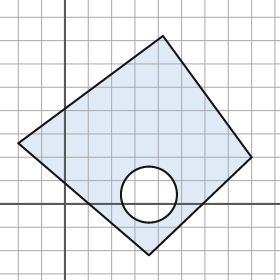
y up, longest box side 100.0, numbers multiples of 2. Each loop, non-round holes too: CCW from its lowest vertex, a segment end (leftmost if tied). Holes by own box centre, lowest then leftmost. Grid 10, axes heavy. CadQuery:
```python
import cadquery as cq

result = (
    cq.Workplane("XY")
    .moveTo(36.0, -22.0)
    .lineTo(80.0, 20.0)
    .lineTo(42.0, 72.0)
    .lineTo(-20.0, 26.0)
    .close()
    .moveTo(36.0, 4.0)
    .circle(12.0)
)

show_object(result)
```